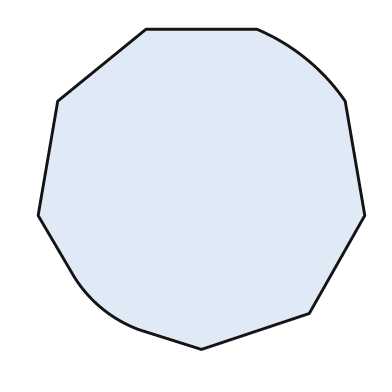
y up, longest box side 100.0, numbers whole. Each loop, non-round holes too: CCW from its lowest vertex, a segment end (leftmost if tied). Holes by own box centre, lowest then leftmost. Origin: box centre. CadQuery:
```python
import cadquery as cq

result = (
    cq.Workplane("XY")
    .moveTo(0.0, -49.0)
    .lineTo(33.0, -38.0)
    .lineTo(50.0, -8.0)
    .lineTo(44.0, 27.0)
    .threePointArc((32.0, 40.0), (17.0, 49.0))
    .lineTo(-17.0, 49.0)
    .lineTo(-44.0, 27.0)
    .lineTo(-50.0, -8.0)
    .lineTo(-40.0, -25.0)
    .threePointArc((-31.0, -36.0), (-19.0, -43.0))
    .close()
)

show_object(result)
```